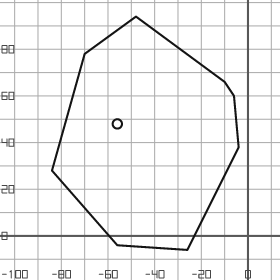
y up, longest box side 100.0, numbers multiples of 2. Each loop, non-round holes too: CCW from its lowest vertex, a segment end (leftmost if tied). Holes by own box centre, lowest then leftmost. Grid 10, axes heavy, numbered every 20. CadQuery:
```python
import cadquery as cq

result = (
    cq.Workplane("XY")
    .moveTo(-26.0, -6.0)
    .lineTo(-4.0, 38.0)
    .lineTo(-6.0, 60.0)
    .lineTo(-10.0, 66.0)
    .lineTo(-48.0, 94.0)
    .lineTo(-70.0, 78.0)
    .lineTo(-84.0, 28.0)
    .lineTo(-56.0, -4.0)
    .close()
    .moveTo(-56.0, 48.0)
    .circle(2.0)
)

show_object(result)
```